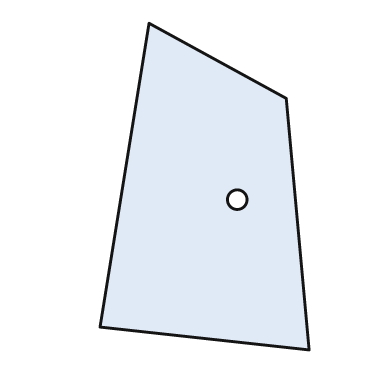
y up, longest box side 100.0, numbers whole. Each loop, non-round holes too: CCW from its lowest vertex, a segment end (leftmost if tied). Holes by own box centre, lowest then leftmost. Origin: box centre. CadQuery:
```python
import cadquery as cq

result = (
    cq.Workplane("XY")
    .moveTo(32.0, -50.0)
    .lineTo(25.0, 27.0)
    .lineTo(-17.0, 50.0)
    .lineTo(-32.0, -43.0)
    .close()
    .moveTo(10.0, -4.0)
    .circle(3.0)
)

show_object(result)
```